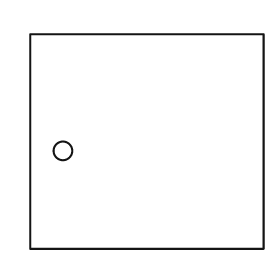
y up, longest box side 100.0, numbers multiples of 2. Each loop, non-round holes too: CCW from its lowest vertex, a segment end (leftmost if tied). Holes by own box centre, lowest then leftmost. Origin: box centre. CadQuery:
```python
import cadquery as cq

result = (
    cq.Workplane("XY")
    .moveTo(-50.0, -46.0)
    .lineTo(50.0, -46.0)
    .lineTo(50.0, 46.0)
    .lineTo(-50.0, 46.0)
    .close()
    .moveTo(-36.0, -4.0)
    .circle(4.0)
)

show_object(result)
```